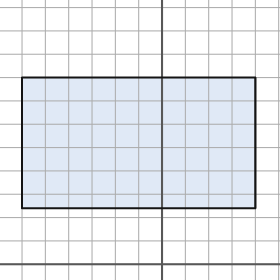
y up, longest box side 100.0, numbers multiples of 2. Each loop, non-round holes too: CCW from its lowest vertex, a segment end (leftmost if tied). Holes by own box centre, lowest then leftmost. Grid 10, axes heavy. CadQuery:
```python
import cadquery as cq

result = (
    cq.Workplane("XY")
    .moveTo(-60.0, 24.0)
    .lineTo(40.0, 24.0)
    .lineTo(40.0, 80.0)
    .lineTo(-60.0, 80.0)
    .close()
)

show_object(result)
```